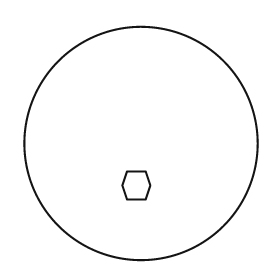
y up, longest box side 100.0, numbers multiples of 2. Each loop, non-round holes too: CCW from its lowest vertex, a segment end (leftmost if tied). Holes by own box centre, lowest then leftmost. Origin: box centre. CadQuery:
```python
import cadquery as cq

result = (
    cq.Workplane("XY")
    .moveTo(0.0, 0.0)
    .circle(50.0)
    .moveTo(-6.0, -24.0)
    .lineTo(2.0, -24.0)
    .lineTo(4.0, -18.0)
    .lineTo(2.0, -12.0)
    .lineTo(-6.0, -12.0)
    .lineTo(-8.0, -18.0)
    .close()
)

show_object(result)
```